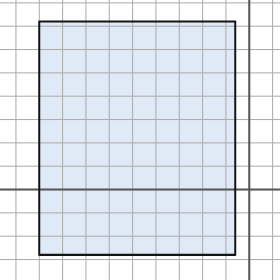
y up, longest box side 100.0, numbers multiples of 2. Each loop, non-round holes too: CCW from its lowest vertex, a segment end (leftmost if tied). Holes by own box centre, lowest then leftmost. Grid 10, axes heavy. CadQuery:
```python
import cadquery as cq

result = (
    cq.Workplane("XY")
    .moveTo(-90.0, -28.0)
    .lineTo(-6.0, -28.0)
    .lineTo(-6.0, 72.0)
    .lineTo(-90.0, 72.0)
    .close()
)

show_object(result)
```